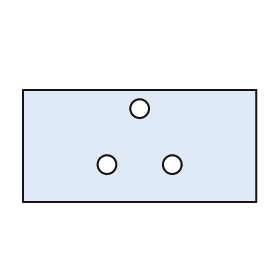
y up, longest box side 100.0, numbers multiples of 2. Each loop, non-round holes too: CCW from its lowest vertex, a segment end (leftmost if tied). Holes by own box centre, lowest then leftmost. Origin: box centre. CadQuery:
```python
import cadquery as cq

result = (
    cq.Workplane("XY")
    .moveTo(-50.0, -24.0)
    .lineTo(50.0, -24.0)
    .lineTo(50.0, 24.0)
    .lineTo(-50.0, 24.0)
    .close()
    .moveTo(-14.0, -8.0)
    .circle(4.0)
    .moveTo(14.0, -8.0)
    .circle(4.0)
    .moveTo(0.0, 16.0)
    .circle(4.0)
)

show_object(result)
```